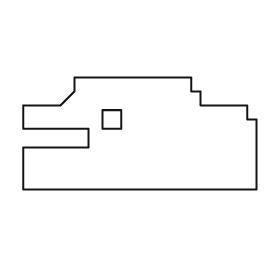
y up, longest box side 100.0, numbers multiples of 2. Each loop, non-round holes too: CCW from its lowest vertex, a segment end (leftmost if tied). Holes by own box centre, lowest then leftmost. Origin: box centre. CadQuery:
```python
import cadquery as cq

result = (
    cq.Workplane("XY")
    .moveTo(-50.0, -24.0)
    .lineTo(50.0, -24.0)
    .lineTo(50.0, 6.0)
    .lineTo(46.0, 6.0)
    .lineTo(46.0, 12.0)
    .lineTo(26.0, 12.0)
    .lineTo(26.0, 18.0)
    .lineTo(22.0, 18.0)
    .lineTo(22.0, 24.0)
    .lineTo(-28.0, 24.0)
    .lineTo(-28.0, 18.0)
    .lineTo(-34.0, 12.0)
    .lineTo(-50.0, 12.0)
    .lineTo(-50.0, 2.0)
    .lineTo(-22.0, 2.0)
    .lineTo(-22.0, -6.0)
    .lineTo(-50.0, -6.0)
    .close()
    .moveTo(-16.0, 2.0)
    .lineTo(-8.0, 2.0)
    .lineTo(-8.0, 10.0)
    .lineTo(-16.0, 10.0)
    .close()
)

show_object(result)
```